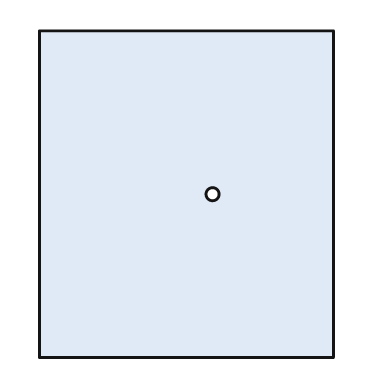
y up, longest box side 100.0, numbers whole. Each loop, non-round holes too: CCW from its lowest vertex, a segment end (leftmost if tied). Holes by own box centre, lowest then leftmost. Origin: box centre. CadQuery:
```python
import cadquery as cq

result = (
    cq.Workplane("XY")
    .moveTo(-45.0, -50.0)
    .lineTo(45.0, -50.0)
    .lineTo(45.0, 50.0)
    .lineTo(-45.0, 50.0)
    .close()
    .moveTo(8.0, 0.0)
    .circle(2.0)
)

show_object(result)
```